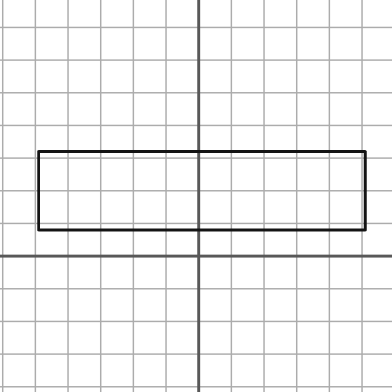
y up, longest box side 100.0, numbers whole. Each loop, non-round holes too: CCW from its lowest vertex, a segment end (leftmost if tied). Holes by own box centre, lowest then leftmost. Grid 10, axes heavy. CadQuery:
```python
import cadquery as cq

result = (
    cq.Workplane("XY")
    .moveTo(-49.0, 8.0)
    .lineTo(51.0, 8.0)
    .lineTo(51.0, 32.0)
    .lineTo(-49.0, 32.0)
    .close()
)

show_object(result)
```